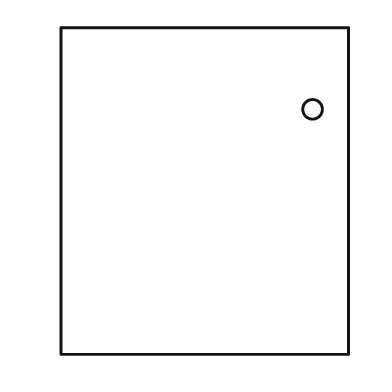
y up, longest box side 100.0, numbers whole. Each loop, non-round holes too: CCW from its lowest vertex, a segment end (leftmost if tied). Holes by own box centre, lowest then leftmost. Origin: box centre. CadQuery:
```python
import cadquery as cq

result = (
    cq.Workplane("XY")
    .moveTo(-44.0, -50.0)
    .lineTo(44.0, -50.0)
    .lineTo(44.0, 50.0)
    .lineTo(-44.0, 50.0)
    .close()
    .moveTo(33.0, 25.0)
    .circle(3.0)
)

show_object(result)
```